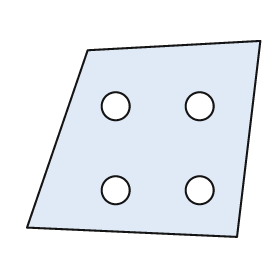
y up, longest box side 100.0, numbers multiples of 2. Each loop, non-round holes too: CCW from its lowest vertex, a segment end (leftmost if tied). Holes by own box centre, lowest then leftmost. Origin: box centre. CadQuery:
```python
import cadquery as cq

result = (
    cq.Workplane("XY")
    .moveTo(40.0, -42.0)
    .lineTo(50.0, 42.0)
    .lineTo(-24.0, 38.0)
    .lineTo(-50.0, -38.0)
    .close()
    .moveTo(-12.0, -22.0)
    .circle(6.0)
    .moveTo(24.0, -22.0)
    .circle(6.0)
    .moveTo(-12.0, 14.0)
    .circle(6.0)
    .moveTo(24.0, 14.0)
    .circle(6.0)
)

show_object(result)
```